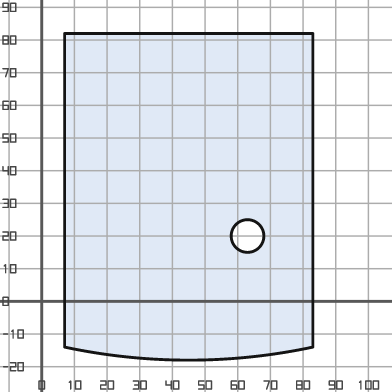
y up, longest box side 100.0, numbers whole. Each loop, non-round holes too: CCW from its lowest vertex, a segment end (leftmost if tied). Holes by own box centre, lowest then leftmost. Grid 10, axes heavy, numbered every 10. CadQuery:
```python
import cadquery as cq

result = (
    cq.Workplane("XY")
    .moveTo(7.0, -14.0)
    .threePointArc((45.0, -18.0), (83.0, -14.0))
    .lineTo(83.0, 82.0)
    .lineTo(7.0, 82.0)
    .close()
    .moveTo(63.0, 20.0)
    .circle(5.0)
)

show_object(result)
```